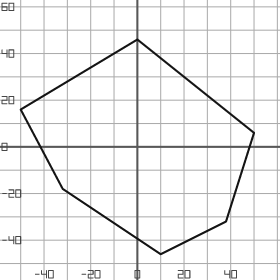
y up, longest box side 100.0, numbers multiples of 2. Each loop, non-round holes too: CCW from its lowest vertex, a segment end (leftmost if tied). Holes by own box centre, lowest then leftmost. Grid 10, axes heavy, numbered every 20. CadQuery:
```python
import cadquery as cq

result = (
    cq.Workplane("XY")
    .moveTo(10.0, -46.0)
    .lineTo(38.0, -32.0)
    .lineTo(50.0, 6.0)
    .lineTo(0.0, 46.0)
    .lineTo(-50.0, 16.0)
    .lineTo(-32.0, -18.0)
    .close()
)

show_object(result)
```